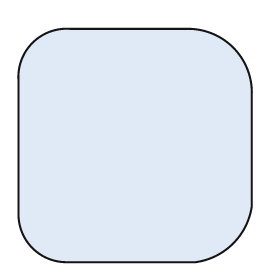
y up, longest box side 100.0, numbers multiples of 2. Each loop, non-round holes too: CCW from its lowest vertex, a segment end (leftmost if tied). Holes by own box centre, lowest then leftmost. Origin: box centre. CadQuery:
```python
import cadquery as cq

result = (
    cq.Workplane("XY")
    .moveTo(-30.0, -50.0)
    .lineTo(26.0, -50.0)
    .threePointArc((42.0, -42.0), (50.0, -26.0))
    .lineTo(50.0, 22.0)
    .threePointArc((42.0, 42.0), (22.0, 50.0))
    .lineTo(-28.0, 50.0)
    .threePointArc((-44.0, 44.0), (-50.0, 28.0))
    .lineTo(-50.0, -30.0)
    .threePointArc((-44.0, -44.0), (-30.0, -50.0))
    .close()
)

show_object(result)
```